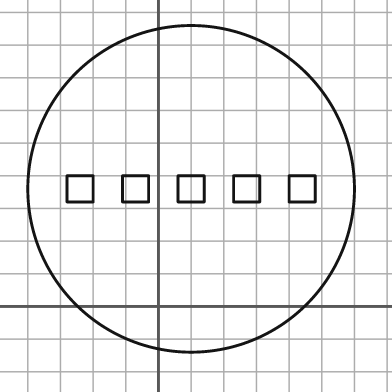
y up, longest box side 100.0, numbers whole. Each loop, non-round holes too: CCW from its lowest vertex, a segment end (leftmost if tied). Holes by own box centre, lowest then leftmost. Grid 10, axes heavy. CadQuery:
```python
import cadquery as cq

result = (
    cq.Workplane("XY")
    .moveTo(10.0, 36.0)
    .circle(50.0)
    .moveTo(-28.0, 32.0)
    .lineTo(-20.0, 32.0)
    .lineTo(-20.0, 40.0)
    .lineTo(-28.0, 40.0)
    .close()
    .moveTo(-11.0, 32.0)
    .lineTo(-3.0, 32.0)
    .lineTo(-3.0, 40.0)
    .lineTo(-11.0, 40.0)
    .close()
    .moveTo(6.0, 32.0)
    .lineTo(14.0, 32.0)
    .lineTo(14.0, 40.0)
    .lineTo(6.0, 40.0)
    .close()
    .moveTo(23.0, 32.0)
    .lineTo(31.0, 32.0)
    .lineTo(31.0, 40.0)
    .lineTo(23.0, 40.0)
    .close()
    .moveTo(40.0, 32.0)
    .lineTo(48.0, 32.0)
    .lineTo(48.0, 40.0)
    .lineTo(40.0, 40.0)
    .close()
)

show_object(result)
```